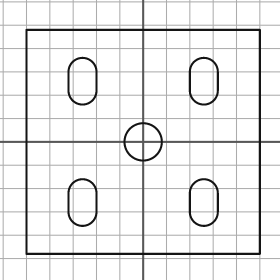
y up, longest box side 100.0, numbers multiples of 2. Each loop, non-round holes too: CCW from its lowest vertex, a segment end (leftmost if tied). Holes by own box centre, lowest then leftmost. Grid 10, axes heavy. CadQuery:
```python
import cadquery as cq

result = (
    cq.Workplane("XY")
    .moveTo(-50.0, -48.0)
    .lineTo(50.0, -48.0)
    .lineTo(50.0, 48.0)
    .lineTo(-50.0, 48.0)
    .close()
    .moveTo(-32.0, -30.0)
    .threePointArc((-26.0, -36.0), (-20.0, -30.0))
    .lineTo(-20.0, -22.0)
    .threePointArc((-26.0, -16.0), (-32.0, -22.0))
    .close()
    .moveTo(20.0, -30.0)
    .threePointArc((26.0, -36.0), (32.0, -30.0))
    .lineTo(32.0, -22.0)
    .threePointArc((26.0, -16.0), (20.0, -22.0))
    .close()
    .moveTo(0.0, 0.0)
    .circle(8.0)
    .moveTo(-32.0, 22.0)
    .threePointArc((-26.0, 16.0), (-20.0, 22.0))
    .lineTo(-20.0, 30.0)
    .threePointArc((-26.0, 36.0), (-32.0, 30.0))
    .close()
    .moveTo(20.0, 22.0)
    .threePointArc((26.0, 16.0), (32.0, 22.0))
    .lineTo(32.0, 30.0)
    .threePointArc((26.0, 36.0), (20.0, 30.0))
    .close()
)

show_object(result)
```